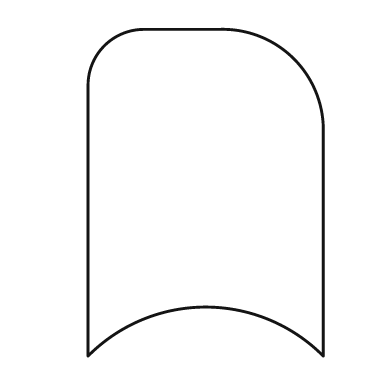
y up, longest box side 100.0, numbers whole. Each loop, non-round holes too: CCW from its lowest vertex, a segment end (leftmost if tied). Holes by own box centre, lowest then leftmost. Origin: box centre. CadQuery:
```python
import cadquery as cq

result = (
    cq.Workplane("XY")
    .moveTo(-36.0, -50.0)
    .threePointArc((0.0, -35.0), (36.0, -50.0))
    .lineTo(36.0, 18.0)
    .threePointArc((27.0, 41.0), (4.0, 50.0))
    .lineTo(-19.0, 50.0)
    .threePointArc((-31.0, 45.0), (-36.0, 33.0))
    .close()
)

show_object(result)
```